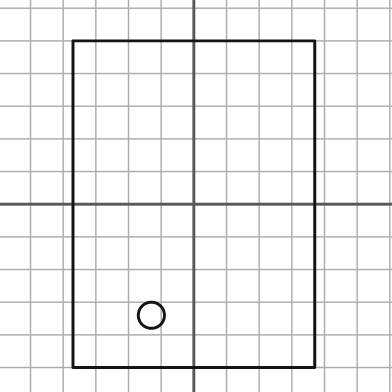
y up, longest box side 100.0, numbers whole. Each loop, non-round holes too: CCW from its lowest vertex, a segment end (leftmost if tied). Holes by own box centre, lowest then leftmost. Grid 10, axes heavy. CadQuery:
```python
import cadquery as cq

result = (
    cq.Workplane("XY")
    .moveTo(-37.0, -50.0)
    .lineTo(37.0, -50.0)
    .lineTo(37.0, 50.0)
    .lineTo(-37.0, 50.0)
    .close()
    .moveTo(-13.0, -34.0)
    .circle(4.0)
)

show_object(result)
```